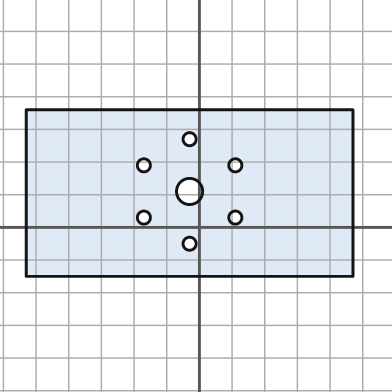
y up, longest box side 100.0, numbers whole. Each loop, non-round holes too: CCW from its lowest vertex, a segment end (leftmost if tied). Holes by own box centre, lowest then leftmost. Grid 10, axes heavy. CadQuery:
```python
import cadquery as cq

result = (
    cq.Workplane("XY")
    .moveTo(-53.0, -15.0)
    .lineTo(47.0, -15.0)
    .lineTo(47.0, 36.0)
    .lineTo(-53.0, 36.0)
    .close()
    .moveTo(-3.0, -5.0)
    .circle(2.0)
    .moveTo(-17.0, 3.0)
    .circle(2.0)
    .moveTo(11.0, 3.0)
    .circle(2.0)
    .moveTo(-3.0, 11.0)
    .circle(4.0)
    .moveTo(-17.0, 19.0)
    .circle(2.0)
    .moveTo(11.0, 19.0)
    .circle(2.0)
    .moveTo(-3.0, 27.0)
    .circle(2.0)
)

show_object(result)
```